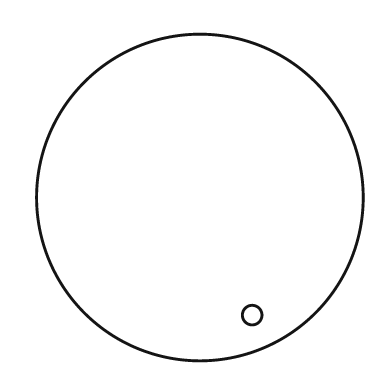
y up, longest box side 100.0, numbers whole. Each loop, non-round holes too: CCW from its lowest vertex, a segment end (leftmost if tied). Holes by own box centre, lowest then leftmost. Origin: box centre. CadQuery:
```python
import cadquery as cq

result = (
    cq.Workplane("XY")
    .moveTo(0.0, 0.0)
    .circle(50.0)
    .moveTo(16.0, -36.0)
    .circle(3.0)
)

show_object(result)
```